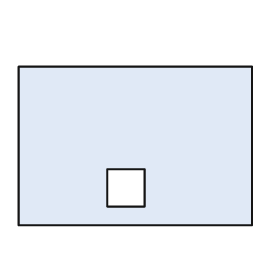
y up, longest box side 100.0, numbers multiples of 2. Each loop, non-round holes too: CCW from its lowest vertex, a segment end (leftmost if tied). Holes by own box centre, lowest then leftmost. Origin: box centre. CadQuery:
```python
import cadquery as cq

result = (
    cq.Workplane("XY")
    .moveTo(-50.0, -34.0)
    .lineTo(50.0, -34.0)
    .lineTo(50.0, 34.0)
    .lineTo(-50.0, 34.0)
    .close()
    .moveTo(-12.0, -26.0)
    .lineTo(4.0, -26.0)
    .lineTo(4.0, -10.0)
    .lineTo(-12.0, -10.0)
    .close()
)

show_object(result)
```